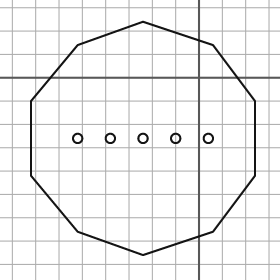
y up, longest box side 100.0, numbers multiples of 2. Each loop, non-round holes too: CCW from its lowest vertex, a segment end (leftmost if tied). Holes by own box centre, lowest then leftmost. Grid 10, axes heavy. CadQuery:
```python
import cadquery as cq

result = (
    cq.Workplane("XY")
    .moveTo(-24.0, -76.0)
    .lineTo(6.0, -66.0)
    .lineTo(24.0, -42.0)
    .lineTo(24.0, -10.0)
    .lineTo(6.0, 14.0)
    .lineTo(-24.0, 24.0)
    .lineTo(-52.0, 14.0)
    .lineTo(-72.0, -10.0)
    .lineTo(-72.0, -42.0)
    .lineTo(-52.0, -66.0)
    .close()
    .moveTo(-52.0, -26.0)
    .circle(2.0)
    .moveTo(-38.0, -26.0)
    .circle(2.0)
    .moveTo(-24.0, -26.0)
    .circle(2.0)
    .moveTo(-10.0, -26.0)
    .circle(2.0)
    .moveTo(4.0, -26.0)
    .circle(2.0)
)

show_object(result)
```